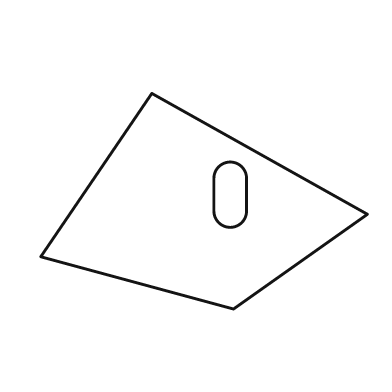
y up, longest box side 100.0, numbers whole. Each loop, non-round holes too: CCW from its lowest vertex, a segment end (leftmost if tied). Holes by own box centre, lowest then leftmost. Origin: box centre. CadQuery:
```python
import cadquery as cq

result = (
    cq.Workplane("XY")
    .moveTo(9.0, -33.0)
    .lineTo(50.0, -4.0)
    .lineTo(-16.0, 33.0)
    .lineTo(-50.0, -17.0)
    .close()
    .moveTo(3.0, -3.0)
    .threePointArc((8.0, -8.0), (13.0, -3.0))
    .lineTo(13.0, 7.0)
    .threePointArc((8.0, 12.0), (3.0, 7.0))
    .close()
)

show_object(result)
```